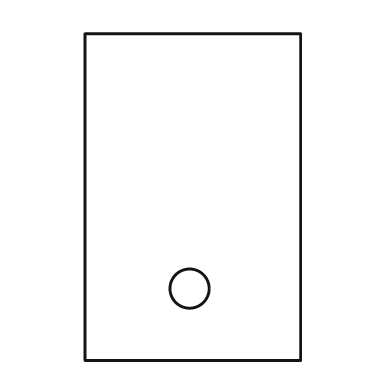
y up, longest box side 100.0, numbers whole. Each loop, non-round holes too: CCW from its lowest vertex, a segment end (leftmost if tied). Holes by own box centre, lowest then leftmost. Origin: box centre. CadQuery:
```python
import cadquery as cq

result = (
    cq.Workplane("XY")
    .moveTo(-33.0, -50.0)
    .lineTo(33.0, -50.0)
    .lineTo(33.0, 50.0)
    .lineTo(-33.0, 50.0)
    .close()
    .moveTo(-1.0, -28.0)
    .circle(6.0)
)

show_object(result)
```